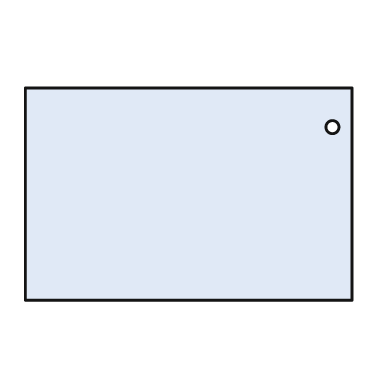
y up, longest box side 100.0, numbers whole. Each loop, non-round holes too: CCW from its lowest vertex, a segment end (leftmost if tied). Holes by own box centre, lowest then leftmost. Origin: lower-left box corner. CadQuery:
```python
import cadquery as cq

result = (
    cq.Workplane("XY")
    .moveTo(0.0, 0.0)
    .lineTo(100.0, 0.0)
    .lineTo(100.0, 65.0)
    .lineTo(0.0, 65.0)
    .close()
    .moveTo(94.0, 53.0)
    .circle(2.0)
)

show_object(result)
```